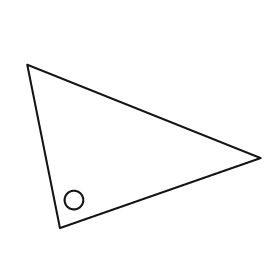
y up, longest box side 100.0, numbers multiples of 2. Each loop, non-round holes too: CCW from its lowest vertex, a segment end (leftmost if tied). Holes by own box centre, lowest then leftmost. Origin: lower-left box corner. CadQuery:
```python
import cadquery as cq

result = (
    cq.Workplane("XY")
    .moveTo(14.0, 0.0)
    .lineTo(100.0, 30.0)
    .lineTo(0.0, 70.0)
    .close()
    .moveTo(20.0, 12.0)
    .circle(4.0)
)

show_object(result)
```